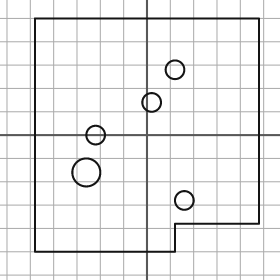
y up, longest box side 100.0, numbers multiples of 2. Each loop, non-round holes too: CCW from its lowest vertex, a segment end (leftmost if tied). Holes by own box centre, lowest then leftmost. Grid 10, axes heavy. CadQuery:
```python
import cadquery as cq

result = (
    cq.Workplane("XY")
    .moveTo(-48.0, -50.0)
    .lineTo(12.0, -50.0)
    .lineTo(12.0, -38.0)
    .lineTo(48.0, -38.0)
    .lineTo(48.0, 50.0)
    .lineTo(-48.0, 50.0)
    .close()
    .moveTo(16.0, -28.0)
    .circle(4.0)
    .moveTo(-26.0, -16.0)
    .circle(6.0)
    .moveTo(-22.0, 0.0)
    .circle(4.0)
    .moveTo(2.0, 14.0)
    .circle(4.0)
    .moveTo(12.0, 28.0)
    .circle(4.0)
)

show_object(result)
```